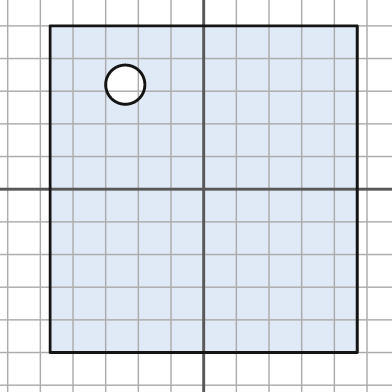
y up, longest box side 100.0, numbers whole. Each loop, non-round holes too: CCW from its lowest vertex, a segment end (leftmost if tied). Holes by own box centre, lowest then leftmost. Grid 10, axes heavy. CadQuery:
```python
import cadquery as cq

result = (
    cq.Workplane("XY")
    .moveTo(-47.0, -50.0)
    .lineTo(47.0, -50.0)
    .lineTo(47.0, 50.0)
    .lineTo(-47.0, 50.0)
    .close()
    .moveTo(-24.0, 32.0)
    .circle(6.0)
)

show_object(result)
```